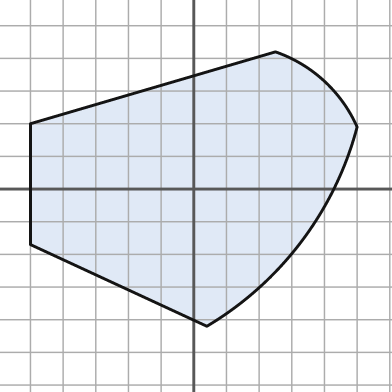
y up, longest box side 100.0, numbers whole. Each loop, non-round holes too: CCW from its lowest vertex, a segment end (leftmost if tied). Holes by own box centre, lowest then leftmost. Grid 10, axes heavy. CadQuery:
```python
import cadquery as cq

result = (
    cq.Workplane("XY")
    .moveTo(4.0, -42.0)
    .threePointArc((33.0, -16.0), (50.0, 19.0))
    .threePointArc((40.0, 33.0), (25.0, 42.0))
    .lineTo(-50.0, 20.0)
    .lineTo(-50.0, -17.0)
    .close()
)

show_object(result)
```